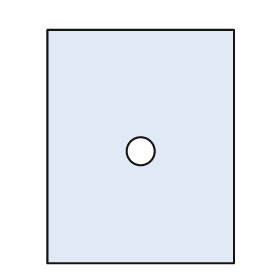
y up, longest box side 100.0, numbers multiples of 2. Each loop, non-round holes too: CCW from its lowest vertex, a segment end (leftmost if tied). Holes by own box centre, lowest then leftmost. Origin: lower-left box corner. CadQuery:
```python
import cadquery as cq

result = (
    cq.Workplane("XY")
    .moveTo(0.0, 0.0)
    .lineTo(80.0, 0.0)
    .lineTo(80.0, 100.0)
    .lineTo(0.0, 100.0)
    .close()
    .moveTo(40.0, 48.0)
    .circle(6.0)
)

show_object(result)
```